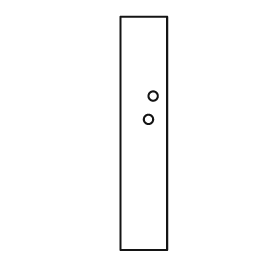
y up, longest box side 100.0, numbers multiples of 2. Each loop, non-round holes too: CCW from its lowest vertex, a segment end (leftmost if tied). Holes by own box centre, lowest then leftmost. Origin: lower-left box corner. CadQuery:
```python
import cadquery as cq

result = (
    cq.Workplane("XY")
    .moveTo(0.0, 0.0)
    .lineTo(20.0, 0.0)
    .lineTo(20.0, 100.0)
    .lineTo(0.0, 100.0)
    .close()
    .moveTo(12.0, 56.0)
    .circle(2.0)
    .moveTo(14.0, 66.0)
    .circle(2.0)
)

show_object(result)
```